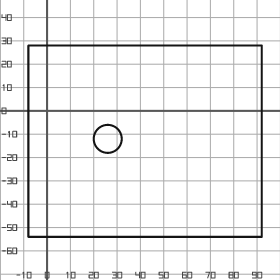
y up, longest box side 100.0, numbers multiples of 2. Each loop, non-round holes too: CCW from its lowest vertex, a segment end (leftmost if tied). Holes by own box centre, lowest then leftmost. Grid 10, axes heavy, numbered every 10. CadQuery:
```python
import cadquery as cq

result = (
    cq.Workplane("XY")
    .moveTo(-8.0, -54.0)
    .lineTo(92.0, -54.0)
    .lineTo(92.0, 28.0)
    .lineTo(-8.0, 28.0)
    .close()
    .moveTo(26.0, -12.0)
    .circle(6.0)
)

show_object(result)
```